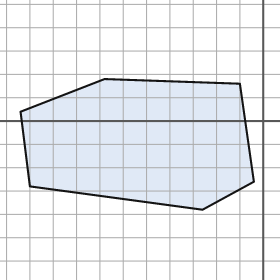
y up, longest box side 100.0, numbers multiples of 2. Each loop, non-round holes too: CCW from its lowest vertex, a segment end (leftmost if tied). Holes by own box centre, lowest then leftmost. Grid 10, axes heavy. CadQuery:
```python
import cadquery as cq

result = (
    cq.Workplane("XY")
    .moveTo(-26.0, -38.0)
    .lineTo(-4.0, -26.0)
    .lineTo(-10.0, 16.0)
    .lineTo(-68.0, 18.0)
    .lineTo(-104.0, 4.0)
    .lineTo(-100.0, -28.0)
    .close()
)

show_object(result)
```